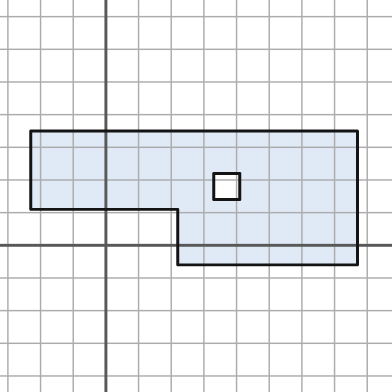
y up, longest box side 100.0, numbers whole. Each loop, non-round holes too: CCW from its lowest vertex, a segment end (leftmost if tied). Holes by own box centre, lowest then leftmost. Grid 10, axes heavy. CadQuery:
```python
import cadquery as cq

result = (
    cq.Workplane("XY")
    .moveTo(22.0, -6.0)
    .lineTo(77.0, -6.0)
    .lineTo(77.0, 35.0)
    .lineTo(-23.0, 35.0)
    .lineTo(-23.0, 11.0)
    .lineTo(22.0, 11.0)
    .close()
    .moveTo(33.0, 14.0)
    .lineTo(41.0, 14.0)
    .lineTo(41.0, 22.0)
    .lineTo(33.0, 22.0)
    .close()
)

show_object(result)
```